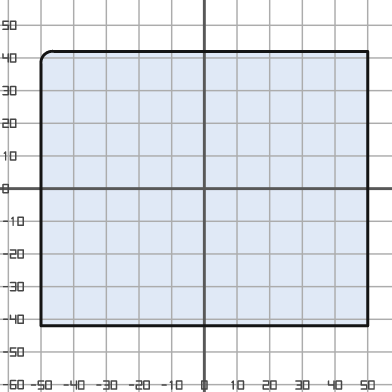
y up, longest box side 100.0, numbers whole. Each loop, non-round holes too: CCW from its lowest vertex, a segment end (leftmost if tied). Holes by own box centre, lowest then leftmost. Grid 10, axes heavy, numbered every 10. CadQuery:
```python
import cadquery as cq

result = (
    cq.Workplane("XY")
    .moveTo(-50.0, -42.0)
    .lineTo(50.0, -42.0)
    .lineTo(50.0, 42.0)
    .lineTo(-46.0, 42.0)
    .threePointArc((-49.0, 41.0), (-50.0, 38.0))
    .close()
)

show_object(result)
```